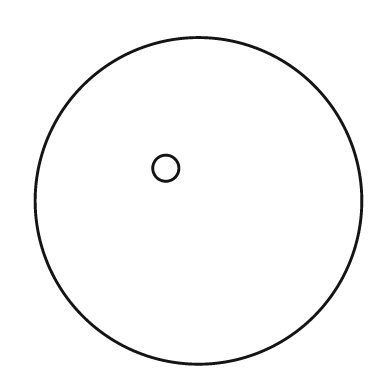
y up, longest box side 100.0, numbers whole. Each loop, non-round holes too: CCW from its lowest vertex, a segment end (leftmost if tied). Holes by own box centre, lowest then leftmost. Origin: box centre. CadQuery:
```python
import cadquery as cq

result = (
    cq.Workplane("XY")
    .moveTo(0.0, 0.0)
    .circle(50.0)
    .moveTo(-10.0, 10.0)
    .circle(4.0)
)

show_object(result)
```